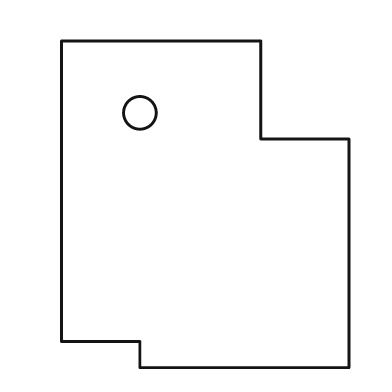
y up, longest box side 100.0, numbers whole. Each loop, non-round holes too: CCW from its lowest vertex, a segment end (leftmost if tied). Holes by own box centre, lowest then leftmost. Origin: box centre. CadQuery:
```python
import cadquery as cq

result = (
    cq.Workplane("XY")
    .moveTo(-20.0, -50.0)
    .lineTo(44.0, -50.0)
    .lineTo(44.0, 20.0)
    .lineTo(17.0, 20.0)
    .lineTo(17.0, 50.0)
    .lineTo(-44.0, 50.0)
    .lineTo(-44.0, -42.0)
    .lineTo(-20.0, -42.0)
    .close()
    .moveTo(-20.0, 28.0)
    .circle(5.0)
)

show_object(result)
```